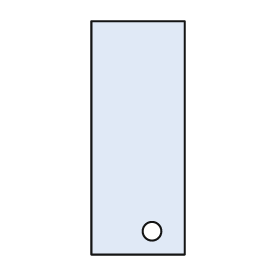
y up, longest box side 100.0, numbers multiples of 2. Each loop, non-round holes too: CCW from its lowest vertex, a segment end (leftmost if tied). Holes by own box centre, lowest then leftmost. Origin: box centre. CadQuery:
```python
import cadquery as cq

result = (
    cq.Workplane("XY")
    .moveTo(-20.0, -50.0)
    .lineTo(20.0, -50.0)
    .lineTo(20.0, 50.0)
    .lineTo(-20.0, 50.0)
    .close()
    .moveTo(6.0, -40.0)
    .circle(4.0)
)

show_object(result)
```